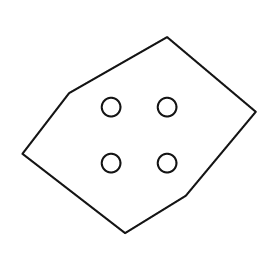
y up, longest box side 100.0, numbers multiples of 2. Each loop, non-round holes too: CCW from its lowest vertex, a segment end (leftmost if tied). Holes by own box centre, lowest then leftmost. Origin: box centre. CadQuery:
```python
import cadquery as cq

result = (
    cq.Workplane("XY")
    .moveTo(-6.0, -42.0)
    .lineTo(20.0, -26.0)
    .lineTo(50.0, 10.0)
    .lineTo(12.0, 42.0)
    .lineTo(-30.0, 18.0)
    .lineTo(-50.0, -8.0)
    .close()
    .moveTo(-12.0, -12.0)
    .circle(4.0)
    .moveTo(12.0, -12.0)
    .circle(4.0)
    .moveTo(-12.0, 12.0)
    .circle(4.0)
    .moveTo(12.0, 12.0)
    .circle(4.0)
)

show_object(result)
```